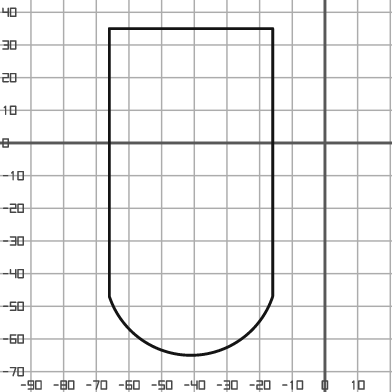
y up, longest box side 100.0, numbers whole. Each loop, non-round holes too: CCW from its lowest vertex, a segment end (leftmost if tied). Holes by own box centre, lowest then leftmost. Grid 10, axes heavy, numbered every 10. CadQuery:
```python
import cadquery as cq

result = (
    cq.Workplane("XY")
    .moveTo(-66.0, -47.0)
    .threePointArc((-41.0, -65.0), (-16.0, -47.0))
    .lineTo(-16.0, 35.0)
    .lineTo(-66.0, 35.0)
    .close()
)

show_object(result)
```